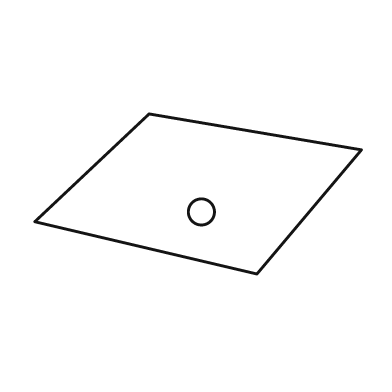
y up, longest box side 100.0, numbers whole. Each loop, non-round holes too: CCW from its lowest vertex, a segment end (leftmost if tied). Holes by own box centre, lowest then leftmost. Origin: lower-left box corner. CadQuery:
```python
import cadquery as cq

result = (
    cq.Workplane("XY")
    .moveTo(68.0, 0.0)
    .lineTo(100.0, 38.0)
    .lineTo(35.0, 49.0)
    .lineTo(0.0, 16.0)
    .close()
    .moveTo(51.0, 19.0)
    .circle(4.0)
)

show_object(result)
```